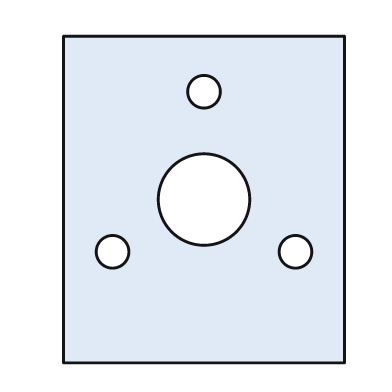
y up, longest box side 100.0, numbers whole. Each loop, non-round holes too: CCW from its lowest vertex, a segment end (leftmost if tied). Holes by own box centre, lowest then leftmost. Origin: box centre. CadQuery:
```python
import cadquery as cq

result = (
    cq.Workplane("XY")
    .moveTo(-43.0, -50.0)
    .lineTo(43.0, -50.0)
    .lineTo(43.0, 50.0)
    .lineTo(-43.0, 50.0)
    .close()
    .moveTo(-28.0, -16.0)
    .circle(5.0)
    .moveTo(28.0, -16.0)
    .circle(5.0)
    .moveTo(0.0, 0.0)
    .circle(14.0)
    .moveTo(0.0, 33.0)
    .circle(5.0)
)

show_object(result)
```